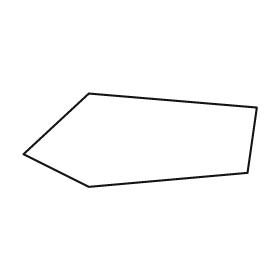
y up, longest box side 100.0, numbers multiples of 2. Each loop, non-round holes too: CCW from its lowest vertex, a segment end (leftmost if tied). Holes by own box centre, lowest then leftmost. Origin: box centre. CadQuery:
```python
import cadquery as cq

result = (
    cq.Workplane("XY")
    .moveTo(-22.0, -20.0)
    .lineTo(46.0, -14.0)
    .lineTo(50.0, 14.0)
    .lineTo(-22.0, 20.0)
    .lineTo(-50.0, -6.0)
    .close()
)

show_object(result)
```